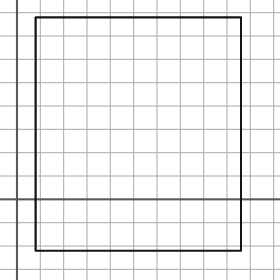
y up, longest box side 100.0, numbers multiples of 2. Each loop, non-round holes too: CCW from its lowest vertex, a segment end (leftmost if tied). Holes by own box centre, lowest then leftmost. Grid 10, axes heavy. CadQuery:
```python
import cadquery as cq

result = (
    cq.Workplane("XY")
    .moveTo(8.0, -22.0)
    .lineTo(96.0, -22.0)
    .lineTo(96.0, 78.0)
    .lineTo(8.0, 78.0)
    .close()
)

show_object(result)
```